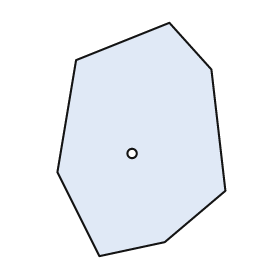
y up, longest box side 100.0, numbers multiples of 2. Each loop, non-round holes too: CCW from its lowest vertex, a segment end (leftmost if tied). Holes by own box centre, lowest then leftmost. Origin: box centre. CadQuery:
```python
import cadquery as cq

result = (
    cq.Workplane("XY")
    .moveTo(-18.0, -50.0)
    .lineTo(10.0, -44.0)
    .lineTo(36.0, -22.0)
    .lineTo(30.0, 30.0)
    .lineTo(12.0, 50.0)
    .lineTo(-28.0, 34.0)
    .lineTo(-36.0, -14.0)
    .close()
    .moveTo(-4.0, -6.0)
    .circle(2.0)
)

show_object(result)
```